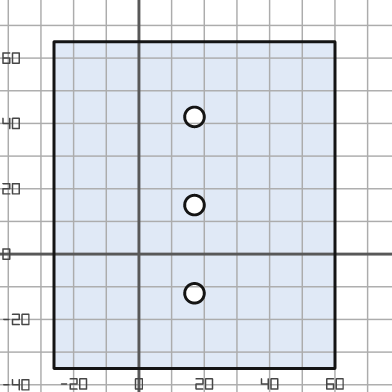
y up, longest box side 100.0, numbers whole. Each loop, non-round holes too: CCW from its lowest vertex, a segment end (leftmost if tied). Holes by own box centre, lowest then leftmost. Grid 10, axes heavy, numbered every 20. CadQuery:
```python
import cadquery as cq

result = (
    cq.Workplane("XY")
    .moveTo(-26.0, -35.0)
    .lineTo(60.0, -35.0)
    .lineTo(60.0, 65.0)
    .lineTo(-26.0, 65.0)
    .close()
    .moveTo(17.0, -12.0)
    .circle(3.0)
    .moveTo(17.0, 15.0)
    .circle(3.0)
    .moveTo(17.0, 42.0)
    .circle(3.0)
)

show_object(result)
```